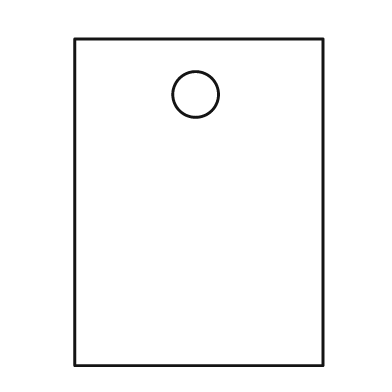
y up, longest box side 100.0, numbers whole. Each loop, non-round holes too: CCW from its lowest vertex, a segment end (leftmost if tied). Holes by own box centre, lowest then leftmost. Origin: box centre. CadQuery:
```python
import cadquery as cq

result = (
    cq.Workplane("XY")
    .moveTo(-38.0, -50.0)
    .lineTo(38.0, -50.0)
    .lineTo(38.0, 50.0)
    .lineTo(-38.0, 50.0)
    .close()
    .moveTo(-1.0, 33.0)
    .circle(7.0)
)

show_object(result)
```